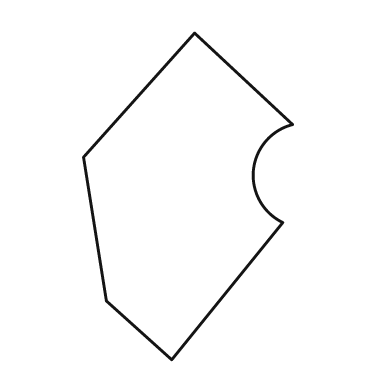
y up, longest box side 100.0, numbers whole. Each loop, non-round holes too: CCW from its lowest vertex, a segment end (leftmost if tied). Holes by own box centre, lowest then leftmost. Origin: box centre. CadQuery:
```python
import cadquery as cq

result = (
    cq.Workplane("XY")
    .moveTo(-5.0, -50.0)
    .lineTo(29.0, -8.0)
    .threePointArc((20.0, 8.0), (32.0, 22.0))
    .lineTo(2.0, 50.0)
    .lineTo(-32.0, 12.0)
    .lineTo(-25.0, -32.0)
    .close()
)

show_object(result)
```